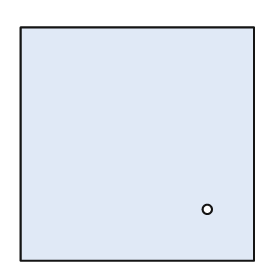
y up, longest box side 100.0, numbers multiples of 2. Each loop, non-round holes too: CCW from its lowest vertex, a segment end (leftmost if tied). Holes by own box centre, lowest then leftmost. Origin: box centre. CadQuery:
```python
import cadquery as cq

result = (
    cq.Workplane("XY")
    .moveTo(-50.0, -50.0)
    .lineTo(50.0, -50.0)
    .lineTo(50.0, 50.0)
    .lineTo(-50.0, 50.0)
    .close()
    .moveTo(30.0, -28.0)
    .circle(2.0)
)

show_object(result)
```